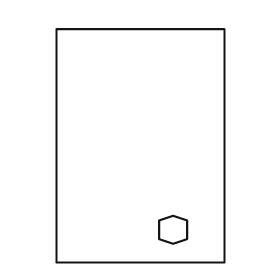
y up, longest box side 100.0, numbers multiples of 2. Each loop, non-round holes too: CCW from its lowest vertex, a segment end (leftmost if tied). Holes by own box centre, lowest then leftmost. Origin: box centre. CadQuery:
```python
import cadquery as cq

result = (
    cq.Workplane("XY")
    .moveTo(-36.0, -50.0)
    .lineTo(36.0, -50.0)
    .lineTo(36.0, 50.0)
    .lineTo(-36.0, 50.0)
    .close()
    .moveTo(14.0, -42.0)
    .lineTo(20.0, -40.0)
    .lineTo(20.0, -32.0)
    .lineTo(14.0, -30.0)
    .lineTo(8.0, -32.0)
    .lineTo(8.0, -40.0)
    .close()
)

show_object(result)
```